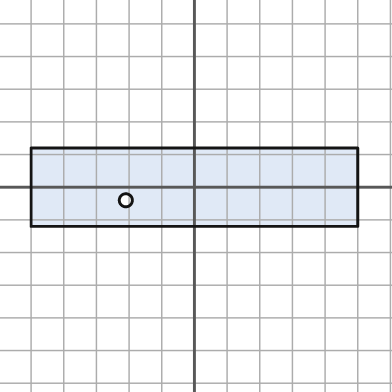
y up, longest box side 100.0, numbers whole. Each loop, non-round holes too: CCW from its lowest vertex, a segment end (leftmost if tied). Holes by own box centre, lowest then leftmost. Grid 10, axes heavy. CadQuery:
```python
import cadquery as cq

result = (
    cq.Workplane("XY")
    .moveTo(-50.0, -12.0)
    .lineTo(50.0, -12.0)
    .lineTo(50.0, 12.0)
    .lineTo(-50.0, 12.0)
    .close()
    .moveTo(-21.0, -4.0)
    .circle(2.0)
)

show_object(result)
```